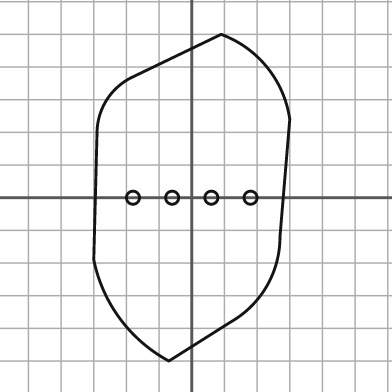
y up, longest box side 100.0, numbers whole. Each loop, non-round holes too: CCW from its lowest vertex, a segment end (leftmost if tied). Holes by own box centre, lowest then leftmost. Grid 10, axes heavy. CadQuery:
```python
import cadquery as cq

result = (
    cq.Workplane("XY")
    .moveTo(-7.0, -50.0)
    .lineTo(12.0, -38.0)
    .threePointArc((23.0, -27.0), (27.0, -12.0))
    .lineTo(30.0, 24.0)
    .threePointArc((23.0, 40.0), (9.0, 50.0))
    .lineTo(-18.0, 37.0)
    .threePointArc((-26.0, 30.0), (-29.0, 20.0))
    .lineTo(-30.0, -19.0)
    .threePointArc((-22.0, -37.0), (-7.0, -50.0))
    .close()
    .moveTo(-18.0, 0.0)
    .circle(2.0)
    .moveTo(-6.0, 0.0)
    .circle(2.0)
    .moveTo(6.0, 0.0)
    .circle(2.0)
    .moveTo(18.0, 0.0)
    .circle(2.0)
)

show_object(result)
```